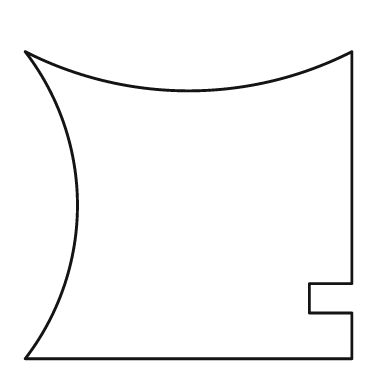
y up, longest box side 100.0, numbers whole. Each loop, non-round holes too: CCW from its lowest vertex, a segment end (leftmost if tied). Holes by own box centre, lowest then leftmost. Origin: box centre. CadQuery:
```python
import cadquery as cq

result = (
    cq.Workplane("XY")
    .moveTo(-50.0, -47.0)
    .lineTo(50.0, -47.0)
    .lineTo(50.0, -33.0)
    .lineTo(37.0, -33.0)
    .lineTo(37.0, -24.0)
    .lineTo(50.0, -24.0)
    .lineTo(50.0, 47.0)
    .threePointArc((0.0, 35.0), (-50.0, 47.0))
    .threePointArc((-34.0, 0.0), (-50.0, -47.0))
    .close()
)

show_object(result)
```